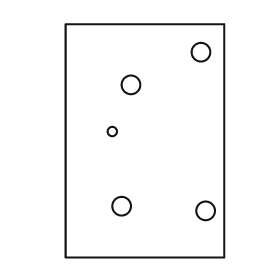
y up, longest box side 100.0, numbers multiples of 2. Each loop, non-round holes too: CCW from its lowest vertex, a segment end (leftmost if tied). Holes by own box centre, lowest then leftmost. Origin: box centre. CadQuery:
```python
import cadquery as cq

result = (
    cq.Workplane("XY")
    .moveTo(-34.0, -50.0)
    .lineTo(34.0, -50.0)
    .lineTo(34.0, 50.0)
    .lineTo(-34.0, 50.0)
    .close()
    .moveTo(26.0, -30.0)
    .circle(4.0)
    .moveTo(-10.0, -28.0)
    .circle(4.0)
    .moveTo(-14.0, 4.0)
    .circle(2.0)
    .moveTo(-6.0, 24.0)
    .circle(4.0)
    .moveTo(24.0, 38.0)
    .circle(4.0)
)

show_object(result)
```